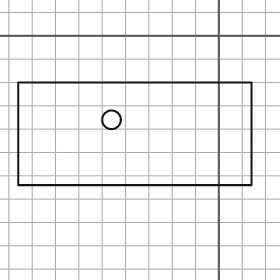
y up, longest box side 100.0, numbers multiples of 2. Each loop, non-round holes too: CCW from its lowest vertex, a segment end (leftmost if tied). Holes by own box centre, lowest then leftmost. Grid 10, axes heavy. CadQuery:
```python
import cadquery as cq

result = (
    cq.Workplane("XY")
    .moveTo(-86.0, -64.0)
    .lineTo(14.0, -64.0)
    .lineTo(14.0, -20.0)
    .lineTo(-86.0, -20.0)
    .close()
    .moveTo(-46.0, -36.0)
    .circle(4.0)
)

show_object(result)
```